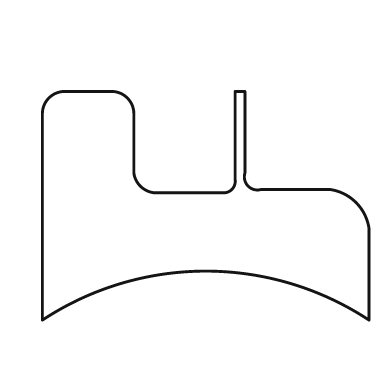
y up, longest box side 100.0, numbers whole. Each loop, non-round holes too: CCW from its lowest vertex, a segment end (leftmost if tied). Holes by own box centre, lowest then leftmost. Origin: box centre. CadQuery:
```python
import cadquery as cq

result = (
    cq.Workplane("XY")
    .moveTo(-50.0, -35.0)
    .threePointArc((0.0, -20.0), (50.0, -35.0))
    .lineTo(50.0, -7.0)
    .threePointArc((46.0, 1.0), (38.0, 5.0))
    .lineTo(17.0, 5.0)
    .threePointArc((13.0, 6.0), (12.0, 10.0))
    .lineTo(12.0, 35.0)
    .lineTo(9.0, 35.0)
    .lineTo(9.0, 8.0)
    .threePointArc((8.0, 5.0), (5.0, 4.0))
    .lineTo(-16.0, 4.0)
    .threePointArc((-20.0, 6.0), (-22.0, 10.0))
    .lineTo(-22.0, 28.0)
    .threePointArc((-24.0, 33.0), (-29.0, 35.0))
    .lineTo(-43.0, 35.0)
    .threePointArc((-48.0, 33.0), (-50.0, 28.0))
    .close()
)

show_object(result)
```